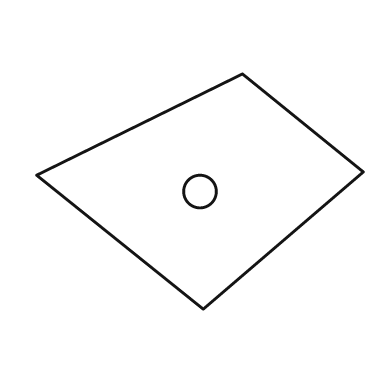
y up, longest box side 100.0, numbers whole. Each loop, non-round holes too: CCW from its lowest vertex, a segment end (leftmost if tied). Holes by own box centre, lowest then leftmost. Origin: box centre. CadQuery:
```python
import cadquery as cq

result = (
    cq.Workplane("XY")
    .moveTo(1.0, -36.0)
    .lineTo(50.0, 6.0)
    .lineTo(13.0, 36.0)
    .lineTo(-50.0, 5.0)
    .close()
    .moveTo(0.0, 0.0)
    .circle(5.0)
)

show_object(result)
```